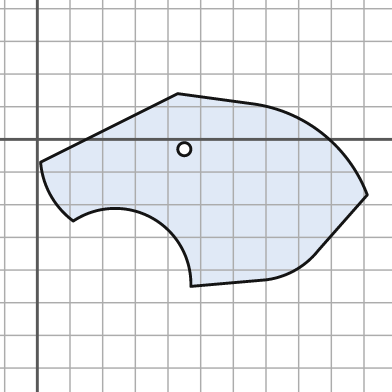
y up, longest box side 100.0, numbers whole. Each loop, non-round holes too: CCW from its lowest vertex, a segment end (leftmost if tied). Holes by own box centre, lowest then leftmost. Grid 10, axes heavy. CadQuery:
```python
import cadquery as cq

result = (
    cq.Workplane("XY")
    .moveTo(47.0, -45.0)
    .lineTo(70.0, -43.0)
    .threePointArc((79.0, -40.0), (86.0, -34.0))
    .lineTo(101.0, -17.0)
    .threePointArc((87.0, 2.0), (65.0, 11.0))
    .lineTo(43.0, 14.0)
    .lineTo(1.0, -7.0)
    .threePointArc((4.0, -17.0), (11.0, -25.0))
    .threePointArc((35.0, -24.0), (47.0, -45.0))
    .close()
    .moveTo(45.0, -3.0)
    .circle(2.0)
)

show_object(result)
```